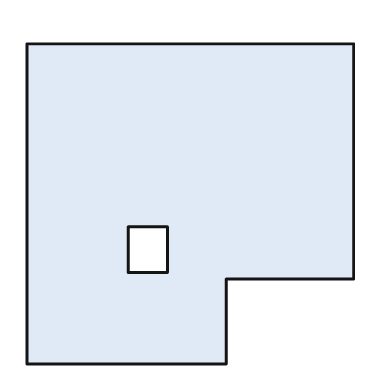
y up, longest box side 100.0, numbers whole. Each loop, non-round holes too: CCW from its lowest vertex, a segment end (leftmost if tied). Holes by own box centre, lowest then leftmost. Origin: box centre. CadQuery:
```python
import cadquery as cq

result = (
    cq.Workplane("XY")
    .moveTo(-50.0, -49.0)
    .lineTo(11.0, -49.0)
    .lineTo(11.0, -23.0)
    .lineTo(50.0, -23.0)
    .lineTo(50.0, 49.0)
    .lineTo(-50.0, 49.0)
    .close()
    .moveTo(-19.0, -21.0)
    .lineTo(-7.0, -21.0)
    .lineTo(-7.0, -7.0)
    .lineTo(-19.0, -7.0)
    .close()
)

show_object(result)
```